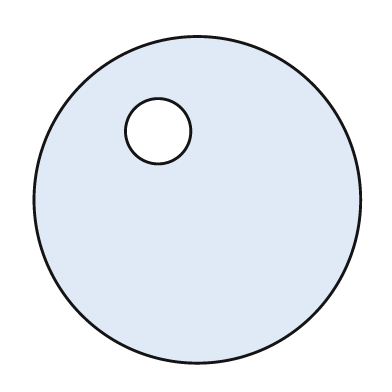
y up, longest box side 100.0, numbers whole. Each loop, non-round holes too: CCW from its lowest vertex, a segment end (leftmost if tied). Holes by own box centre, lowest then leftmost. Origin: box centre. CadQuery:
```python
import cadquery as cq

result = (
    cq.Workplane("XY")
    .moveTo(0.0, 0.0)
    .circle(50.0)
    .moveTo(-12.0, 21.0)
    .circle(10.0)
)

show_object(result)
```